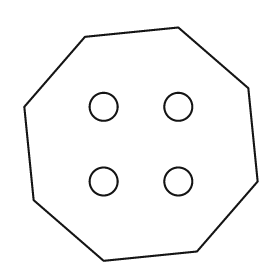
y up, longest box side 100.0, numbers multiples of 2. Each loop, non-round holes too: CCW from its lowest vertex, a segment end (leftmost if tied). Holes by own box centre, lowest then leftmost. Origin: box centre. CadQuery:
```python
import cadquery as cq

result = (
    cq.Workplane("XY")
    .moveTo(-16.0, -50.0)
    .lineTo(24.0, -46.0)
    .lineTo(50.0, -16.0)
    .lineTo(46.0, 24.0)
    .lineTo(16.0, 50.0)
    .lineTo(-24.0, 46.0)
    .lineTo(-50.0, 16.0)
    .lineTo(-46.0, -24.0)
    .close()
    .moveTo(-16.0, -16.0)
    .circle(6.0)
    .moveTo(16.0, -16.0)
    .circle(6.0)
    .moveTo(-16.0, 16.0)
    .circle(6.0)
    .moveTo(16.0, 16.0)
    .circle(6.0)
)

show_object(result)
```